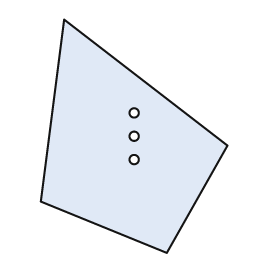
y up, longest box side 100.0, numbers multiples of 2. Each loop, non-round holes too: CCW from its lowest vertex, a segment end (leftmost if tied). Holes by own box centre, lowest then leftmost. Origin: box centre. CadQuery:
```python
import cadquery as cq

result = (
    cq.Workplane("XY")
    .moveTo(14.0, -50.0)
    .lineTo(40.0, -4.0)
    .lineTo(-30.0, 50.0)
    .lineTo(-40.0, -28.0)
    .close()
    .moveTo(0.0, -10.0)
    .circle(2.0)
    .moveTo(0.0, 0.0)
    .circle(2.0)
    .moveTo(0.0, 10.0)
    .circle(2.0)
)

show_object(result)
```